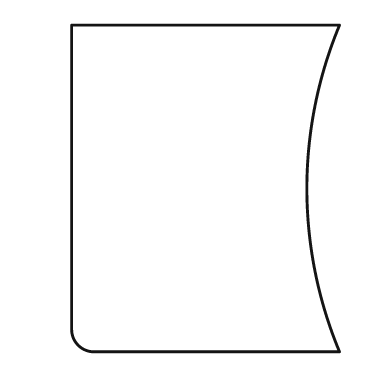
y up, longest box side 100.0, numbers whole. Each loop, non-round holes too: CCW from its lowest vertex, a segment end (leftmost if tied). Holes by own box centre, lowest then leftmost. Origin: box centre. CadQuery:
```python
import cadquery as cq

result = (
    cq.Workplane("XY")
    .moveTo(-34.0, -50.0)
    .lineTo(41.0, -50.0)
    .threePointArc((31.0, 0.0), (41.0, 50.0))
    .lineTo(-41.0, 50.0)
    .lineTo(-41.0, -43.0)
    .threePointArc((-39.0, -48.0), (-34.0, -50.0))
    .close()
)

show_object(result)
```